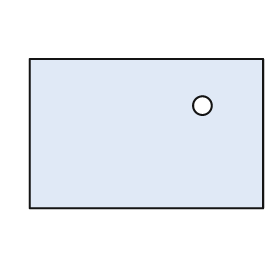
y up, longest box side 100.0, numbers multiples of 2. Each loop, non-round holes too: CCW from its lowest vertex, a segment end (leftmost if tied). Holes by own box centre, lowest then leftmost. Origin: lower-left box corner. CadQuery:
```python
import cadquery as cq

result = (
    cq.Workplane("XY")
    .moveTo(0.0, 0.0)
    .lineTo(100.0, 0.0)
    .lineTo(100.0, 64.0)
    .lineTo(0.0, 64.0)
    .close()
    .moveTo(74.0, 44.0)
    .circle(4.0)
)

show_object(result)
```